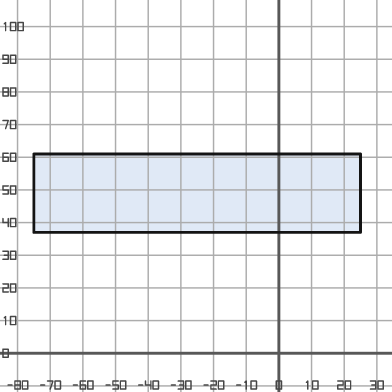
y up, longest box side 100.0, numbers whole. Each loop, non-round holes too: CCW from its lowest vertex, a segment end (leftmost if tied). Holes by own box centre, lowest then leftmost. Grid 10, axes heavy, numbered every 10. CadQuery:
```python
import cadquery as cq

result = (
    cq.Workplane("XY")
    .moveTo(-75.0, 37.0)
    .lineTo(25.0, 37.0)
    .lineTo(25.0, 61.0)
    .lineTo(-75.0, 61.0)
    .close()
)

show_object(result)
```